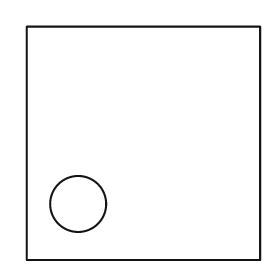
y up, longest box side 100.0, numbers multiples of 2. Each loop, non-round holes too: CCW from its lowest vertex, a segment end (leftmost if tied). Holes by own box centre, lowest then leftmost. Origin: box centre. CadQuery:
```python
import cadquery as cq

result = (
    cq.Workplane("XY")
    .moveTo(-50.0, -50.0)
    .lineTo(50.0, -50.0)
    .lineTo(50.0, 50.0)
    .lineTo(-50.0, 50.0)
    .close()
    .moveTo(-28.0, -26.0)
    .circle(12.0)
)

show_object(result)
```